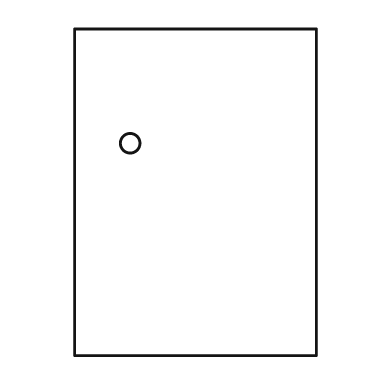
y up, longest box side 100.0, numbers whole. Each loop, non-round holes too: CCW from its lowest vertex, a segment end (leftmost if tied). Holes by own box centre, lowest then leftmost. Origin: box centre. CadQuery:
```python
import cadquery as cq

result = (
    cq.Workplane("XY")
    .moveTo(-37.0, -50.0)
    .lineTo(37.0, -50.0)
    .lineTo(37.0, 50.0)
    .lineTo(-37.0, 50.0)
    .close()
    .moveTo(-20.0, 15.0)
    .circle(3.0)
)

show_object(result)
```